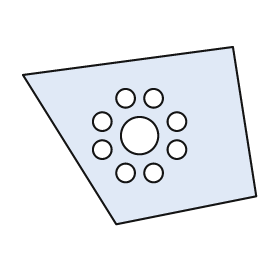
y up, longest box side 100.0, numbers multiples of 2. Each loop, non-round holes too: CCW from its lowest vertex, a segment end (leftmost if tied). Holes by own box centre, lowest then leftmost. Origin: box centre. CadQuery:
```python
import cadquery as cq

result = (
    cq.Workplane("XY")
    .moveTo(-10.0, -38.0)
    .lineTo(50.0, -26.0)
    .lineTo(40.0, 38.0)
    .lineTo(-50.0, 26.0)
    .close()
    .moveTo(-6.0, -16.0)
    .circle(4.0)
    .moveTo(6.0, -16.0)
    .circle(4.0)
    .moveTo(-16.0, -6.0)
    .circle(4.0)
    .moveTo(16.0, -6.0)
    .circle(4.0)
    .moveTo(0.0, 0.0)
    .circle(8.0)
    .moveTo(-16.0, 6.0)
    .circle(4.0)
    .moveTo(16.0, 6.0)
    .circle(4.0)
    .moveTo(-6.0, 16.0)
    .circle(4.0)
    .moveTo(6.0, 16.0)
    .circle(4.0)
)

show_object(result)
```